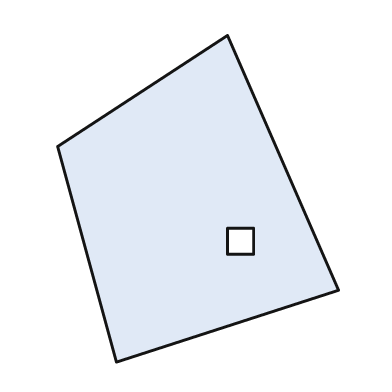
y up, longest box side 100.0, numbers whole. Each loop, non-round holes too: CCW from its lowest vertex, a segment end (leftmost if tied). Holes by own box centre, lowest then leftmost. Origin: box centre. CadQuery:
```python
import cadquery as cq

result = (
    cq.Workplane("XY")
    .moveTo(-25.0, -50.0)
    .lineTo(43.0, -28.0)
    .lineTo(9.0, 50.0)
    .lineTo(-43.0, 16.0)
    .close()
    .moveTo(9.0, -17.0)
    .lineTo(17.0, -17.0)
    .lineTo(17.0, -9.0)
    .lineTo(9.0, -9.0)
    .close()
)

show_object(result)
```